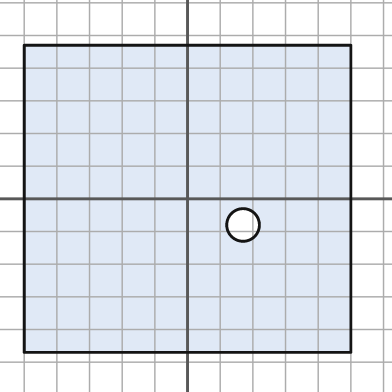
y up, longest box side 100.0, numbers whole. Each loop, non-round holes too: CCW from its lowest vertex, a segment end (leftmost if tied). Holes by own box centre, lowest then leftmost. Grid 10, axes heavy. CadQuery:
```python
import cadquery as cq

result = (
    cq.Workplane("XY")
    .moveTo(-50.0, -47.0)
    .lineTo(50.0, -47.0)
    .lineTo(50.0, 47.0)
    .lineTo(-50.0, 47.0)
    .close()
    .moveTo(17.0, -8.0)
    .circle(5.0)
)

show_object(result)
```